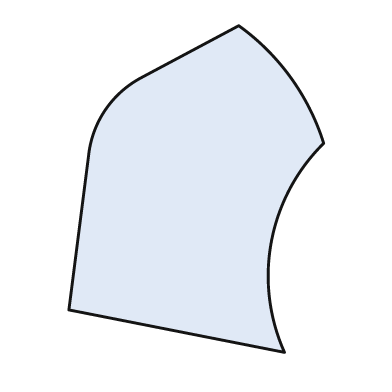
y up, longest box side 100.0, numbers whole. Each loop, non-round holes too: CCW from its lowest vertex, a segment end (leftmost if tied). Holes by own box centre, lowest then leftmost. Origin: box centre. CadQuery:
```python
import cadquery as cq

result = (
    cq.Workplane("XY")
    .moveTo(27.0, -50.0)
    .threePointArc((23.0, -16.0), (39.0, 14.0))
    .threePointArc((29.0, 34.0), (13.0, 50.0))
    .lineTo(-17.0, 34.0)
    .threePointArc((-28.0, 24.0), (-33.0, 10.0))
    .lineTo(-39.0, -37.0)
    .close()
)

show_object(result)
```